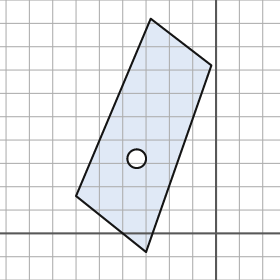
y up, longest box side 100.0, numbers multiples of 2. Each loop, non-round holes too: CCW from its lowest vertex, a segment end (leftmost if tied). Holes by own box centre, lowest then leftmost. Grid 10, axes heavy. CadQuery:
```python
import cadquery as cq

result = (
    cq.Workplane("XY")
    .moveTo(-30.0, -8.0)
    .lineTo(-2.0, 72.0)
    .lineTo(-28.0, 92.0)
    .lineTo(-60.0, 16.0)
    .close()
    .moveTo(-34.0, 32.0)
    .circle(4.0)
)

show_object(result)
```